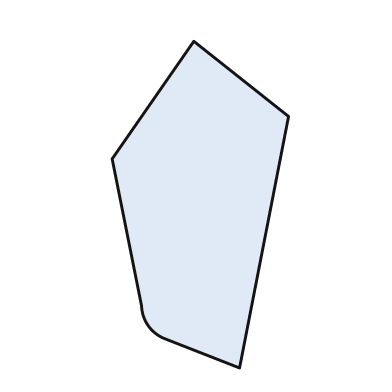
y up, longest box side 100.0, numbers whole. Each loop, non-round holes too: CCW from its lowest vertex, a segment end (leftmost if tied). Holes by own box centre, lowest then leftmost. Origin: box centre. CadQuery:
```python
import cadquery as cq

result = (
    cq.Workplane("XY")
    .moveTo(12.0, -50.0)
    .lineTo(27.0, 27.0)
    .lineTo(-2.0, 50.0)
    .lineTo(-27.0, 14.0)
    .lineTo(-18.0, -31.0)
    .threePointArc((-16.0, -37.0), (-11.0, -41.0))
    .close()
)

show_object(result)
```